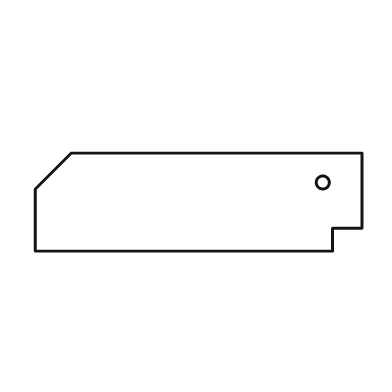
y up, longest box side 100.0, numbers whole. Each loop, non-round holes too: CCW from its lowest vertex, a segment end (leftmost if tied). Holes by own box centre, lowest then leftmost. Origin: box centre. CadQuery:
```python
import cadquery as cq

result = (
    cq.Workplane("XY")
    .moveTo(-50.0, -15.0)
    .lineTo(41.0, -15.0)
    .lineTo(41.0, -8.0)
    .lineTo(50.0, -8.0)
    .lineTo(50.0, 15.0)
    .lineTo(-39.0, 15.0)
    .lineTo(-50.0, 4.0)
    .close()
    .moveTo(38.0, 6.0)
    .circle(2.0)
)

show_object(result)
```